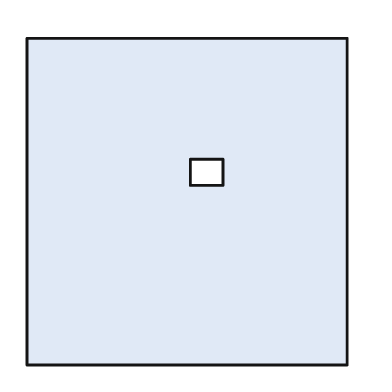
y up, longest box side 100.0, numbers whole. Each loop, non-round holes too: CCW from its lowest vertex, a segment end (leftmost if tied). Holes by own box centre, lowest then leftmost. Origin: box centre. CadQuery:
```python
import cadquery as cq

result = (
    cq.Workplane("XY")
    .moveTo(-49.0, -50.0)
    .lineTo(49.0, -50.0)
    .lineTo(49.0, 50.0)
    .lineTo(-49.0, 50.0)
    .close()
    .moveTo(1.0, 5.0)
    .lineTo(11.0, 5.0)
    .lineTo(11.0, 13.0)
    .lineTo(1.0, 13.0)
    .close()
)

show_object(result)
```